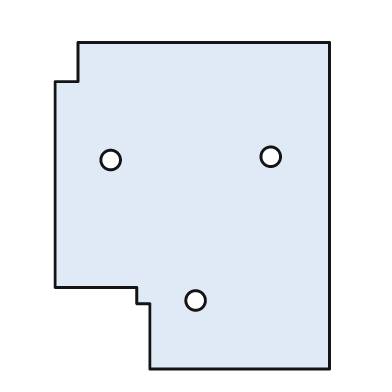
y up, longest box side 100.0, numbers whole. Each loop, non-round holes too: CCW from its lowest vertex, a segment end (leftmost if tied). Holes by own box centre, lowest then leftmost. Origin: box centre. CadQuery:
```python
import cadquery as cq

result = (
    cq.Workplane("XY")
    .moveTo(-13.0, -50.0)
    .lineTo(42.0, -50.0)
    .lineTo(42.0, 50.0)
    .lineTo(-35.0, 50.0)
    .lineTo(-35.0, 38.0)
    .lineTo(-42.0, 38.0)
    .lineTo(-42.0, -25.0)
    .lineTo(-17.0, -25.0)
    .lineTo(-17.0, -30.0)
    .lineTo(-13.0, -30.0)
    .close()
    .moveTo(1.0, -29.0)
    .circle(3.0)
    .moveTo(-25.0, 14.0)
    .circle(3.0)
    .moveTo(24.0, 15.0)
    .circle(3.0)
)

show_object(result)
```